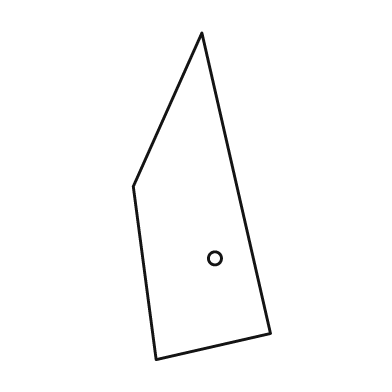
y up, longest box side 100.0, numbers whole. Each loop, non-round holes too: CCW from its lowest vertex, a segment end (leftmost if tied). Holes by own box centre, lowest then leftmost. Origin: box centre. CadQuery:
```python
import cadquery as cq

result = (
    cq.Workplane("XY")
    .moveTo(-14.0, -50.0)
    .lineTo(21.0, -42.0)
    .lineTo(0.0, 50.0)
    .lineTo(-21.0, 3.0)
    .close()
    .moveTo(4.0, -19.0)
    .circle(2.0)
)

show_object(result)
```